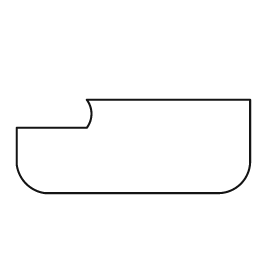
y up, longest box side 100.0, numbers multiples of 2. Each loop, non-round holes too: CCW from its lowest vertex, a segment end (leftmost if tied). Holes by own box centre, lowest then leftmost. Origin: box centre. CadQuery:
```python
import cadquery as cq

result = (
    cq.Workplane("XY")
    .moveTo(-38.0, -20.0)
    .lineTo(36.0, -20.0)
    .threePointArc((46.0, -16.0), (50.0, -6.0))
    .lineTo(50.0, 20.0)
    .lineTo(-20.0, 20.0)
    .threePointArc((-18.0, 14.0), (-20.0, 8.0))
    .lineTo(-50.0, 8.0)
    .lineTo(-50.0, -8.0)
    .threePointArc((-46.0, -16.0), (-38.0, -20.0))
    .close()
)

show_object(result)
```